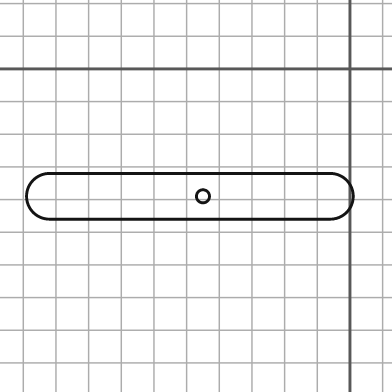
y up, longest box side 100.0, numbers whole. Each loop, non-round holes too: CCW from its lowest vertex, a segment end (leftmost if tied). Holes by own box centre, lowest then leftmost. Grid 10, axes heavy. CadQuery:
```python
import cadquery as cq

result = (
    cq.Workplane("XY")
    .moveTo(-92.0, -46.0)
    .lineTo(-6.0, -46.0)
    .threePointArc((1.0, -39.0), (-6.0, -32.0))
    .lineTo(-92.0, -32.0)
    .threePointArc((-99.0, -39.0), (-92.0, -46.0))
    .close()
    .moveTo(-45.0, -39.0)
    .circle(2.0)
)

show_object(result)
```